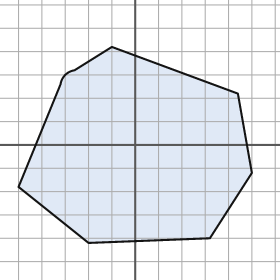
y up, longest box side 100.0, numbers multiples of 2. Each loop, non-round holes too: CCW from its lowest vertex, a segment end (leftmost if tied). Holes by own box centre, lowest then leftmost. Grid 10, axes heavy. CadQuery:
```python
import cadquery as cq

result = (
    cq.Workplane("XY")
    .moveTo(-20.0, -42.0)
    .lineTo(32.0, -40.0)
    .lineTo(50.0, -12.0)
    .lineTo(44.0, 22.0)
    .lineTo(-10.0, 42.0)
    .lineTo(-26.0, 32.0)
    .threePointArc((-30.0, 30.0), (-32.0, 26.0))
    .lineTo(-50.0, -18.0)
    .close()
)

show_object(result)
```